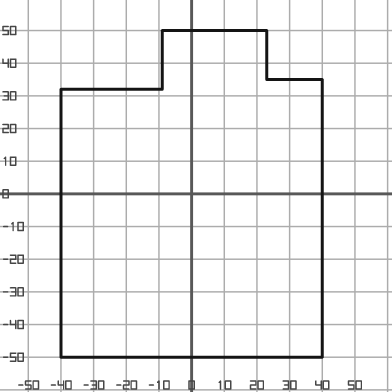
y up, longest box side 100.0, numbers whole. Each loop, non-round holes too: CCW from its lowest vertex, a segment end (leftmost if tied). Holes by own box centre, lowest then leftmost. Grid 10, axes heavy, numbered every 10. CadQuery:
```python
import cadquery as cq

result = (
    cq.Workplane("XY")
    .moveTo(-40.0, -50.0)
    .lineTo(40.0, -50.0)
    .lineTo(40.0, 35.0)
    .lineTo(23.0, 35.0)
    .lineTo(23.0, 50.0)
    .lineTo(-9.0, 50.0)
    .lineTo(-9.0, 32.0)
    .lineTo(-40.0, 32.0)
    .close()
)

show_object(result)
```